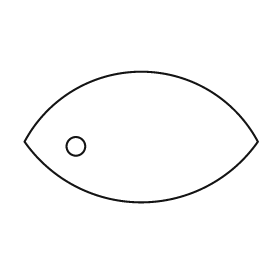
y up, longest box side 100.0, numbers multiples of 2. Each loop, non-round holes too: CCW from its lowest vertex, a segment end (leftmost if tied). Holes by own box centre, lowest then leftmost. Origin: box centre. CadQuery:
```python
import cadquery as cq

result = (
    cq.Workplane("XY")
    .moveTo(-50.0, -2.0)
    .threePointArc((0.0, -28.0), (50.0, -2.0))
    .threePointArc((0.0, 28.0), (-50.0, -2.0))
    .close()
    .moveTo(-28.0, -4.0)
    .circle(4.0)
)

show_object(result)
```